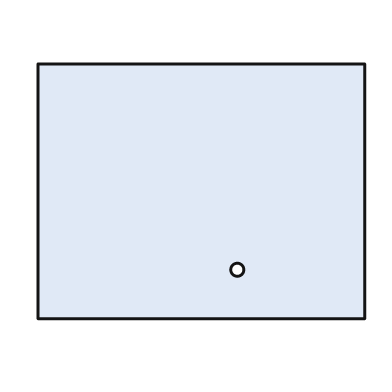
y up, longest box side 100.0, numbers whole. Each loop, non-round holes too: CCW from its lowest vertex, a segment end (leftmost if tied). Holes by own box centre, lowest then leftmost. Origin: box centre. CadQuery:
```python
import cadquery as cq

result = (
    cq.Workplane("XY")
    .moveTo(-50.0, -39.0)
    .lineTo(50.0, -39.0)
    .lineTo(50.0, 39.0)
    .lineTo(-50.0, 39.0)
    .close()
    .moveTo(11.0, -24.0)
    .circle(2.0)
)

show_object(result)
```